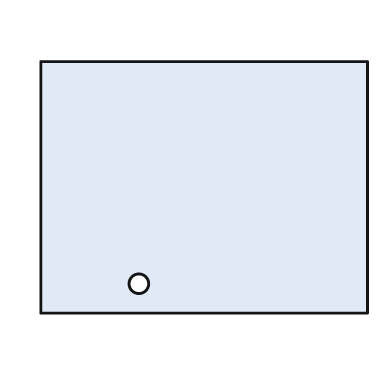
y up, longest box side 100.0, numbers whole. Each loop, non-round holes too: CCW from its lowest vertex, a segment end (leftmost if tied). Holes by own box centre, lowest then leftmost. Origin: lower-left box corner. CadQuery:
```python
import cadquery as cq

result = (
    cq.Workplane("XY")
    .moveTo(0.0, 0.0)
    .lineTo(100.0, 0.0)
    .lineTo(100.0, 77.0)
    .lineTo(0.0, 77.0)
    .close()
    .moveTo(30.0, 9.0)
    .circle(3.0)
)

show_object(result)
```